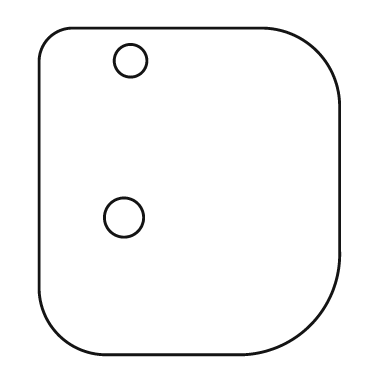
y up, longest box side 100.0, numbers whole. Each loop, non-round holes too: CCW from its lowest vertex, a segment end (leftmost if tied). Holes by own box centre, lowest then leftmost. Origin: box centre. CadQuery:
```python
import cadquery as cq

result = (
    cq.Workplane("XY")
    .moveTo(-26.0, -50.0)
    .lineTo(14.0, -50.0)
    .threePointArc((37.0, -41.0), (46.0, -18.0))
    .lineTo(46.0, 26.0)
    .threePointArc((39.0, 43.0), (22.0, 50.0))
    .lineTo(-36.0, 50.0)
    .threePointArc((-43.0, 47.0), (-46.0, 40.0))
    .lineTo(-46.0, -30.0)
    .threePointArc((-40.0, -44.0), (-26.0, -50.0))
    .close()
    .moveTo(-20.0, -8.0)
    .circle(6.0)
    .moveTo(-18.0, 40.0)
    .circle(5.0)
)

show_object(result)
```